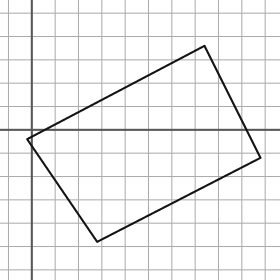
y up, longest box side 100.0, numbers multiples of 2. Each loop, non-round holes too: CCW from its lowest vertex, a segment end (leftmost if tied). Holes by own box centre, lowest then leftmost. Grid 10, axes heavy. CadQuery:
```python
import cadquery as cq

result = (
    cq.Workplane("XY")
    .moveTo(28.0, -48.0)
    .lineTo(98.0, -12.0)
    .lineTo(74.0, 36.0)
    .lineTo(-2.0, -4.0)
    .close()
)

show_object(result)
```